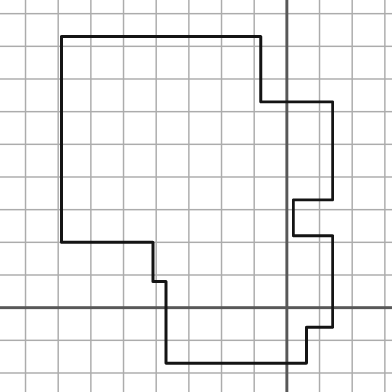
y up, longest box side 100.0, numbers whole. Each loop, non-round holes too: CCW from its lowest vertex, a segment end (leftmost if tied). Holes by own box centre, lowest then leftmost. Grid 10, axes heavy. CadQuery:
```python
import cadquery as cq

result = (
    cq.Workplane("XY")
    .moveTo(-37.0, -17.0)
    .lineTo(6.0, -17.0)
    .lineTo(6.0, -6.0)
    .lineTo(14.0, -6.0)
    .lineTo(14.0, 22.0)
    .lineTo(2.0, 22.0)
    .lineTo(2.0, 33.0)
    .lineTo(14.0, 33.0)
    .lineTo(14.0, 63.0)
    .lineTo(-8.0, 63.0)
    .lineTo(-8.0, 83.0)
    .lineTo(-69.0, 83.0)
    .lineTo(-69.0, 20.0)
    .lineTo(-41.0, 20.0)
    .lineTo(-41.0, 8.0)
    .lineTo(-37.0, 8.0)
    .close()
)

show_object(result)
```